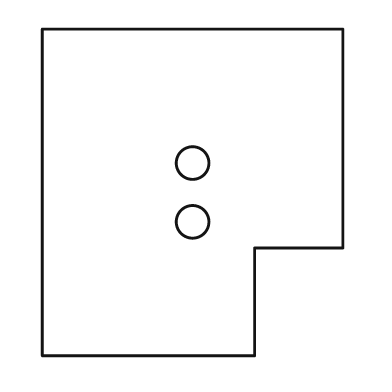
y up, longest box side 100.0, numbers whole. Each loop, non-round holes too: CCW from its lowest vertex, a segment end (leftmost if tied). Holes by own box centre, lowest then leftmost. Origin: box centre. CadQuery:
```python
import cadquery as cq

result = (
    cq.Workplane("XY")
    .moveTo(-46.0, -50.0)
    .lineTo(19.0, -50.0)
    .lineTo(19.0, -17.0)
    .lineTo(46.0, -17.0)
    .lineTo(46.0, 50.0)
    .lineTo(-46.0, 50.0)
    .close()
    .moveTo(0.0, -9.0)
    .circle(5.0)
    .moveTo(0.0, 9.0)
    .circle(5.0)
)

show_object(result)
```